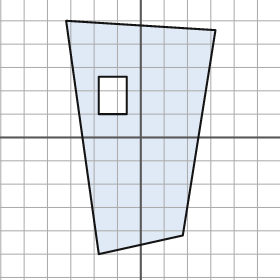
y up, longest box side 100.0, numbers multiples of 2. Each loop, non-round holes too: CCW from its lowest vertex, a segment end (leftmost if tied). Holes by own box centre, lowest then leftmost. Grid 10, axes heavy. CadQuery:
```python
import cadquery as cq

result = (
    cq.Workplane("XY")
    .moveTo(-18.0, -50.0)
    .lineTo(18.0, -42.0)
    .lineTo(32.0, 46.0)
    .lineTo(-32.0, 50.0)
    .close()
    .moveTo(-18.0, 10.0)
    .lineTo(-6.0, 10.0)
    .lineTo(-6.0, 26.0)
    .lineTo(-18.0, 26.0)
    .close()
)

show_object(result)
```